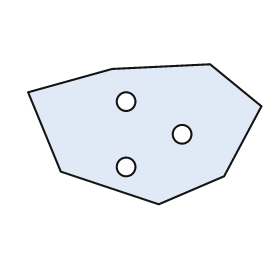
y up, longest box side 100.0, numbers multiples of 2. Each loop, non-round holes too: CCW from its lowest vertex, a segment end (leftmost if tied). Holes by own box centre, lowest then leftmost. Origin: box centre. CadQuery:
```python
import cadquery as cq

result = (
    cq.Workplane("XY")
    .moveTo(6.0, -30.0)
    .lineTo(34.0, -18.0)
    .lineTo(50.0, 12.0)
    .lineTo(28.0, 30.0)
    .lineTo(-14.0, 28.0)
    .lineTo(-50.0, 18.0)
    .lineTo(-36.0, -16.0)
    .close()
    .moveTo(-8.0, -14.0)
    .circle(4.0)
    .moveTo(16.0, 0.0)
    .circle(4.0)
    .moveTo(-8.0, 14.0)
    .circle(4.0)
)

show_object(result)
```